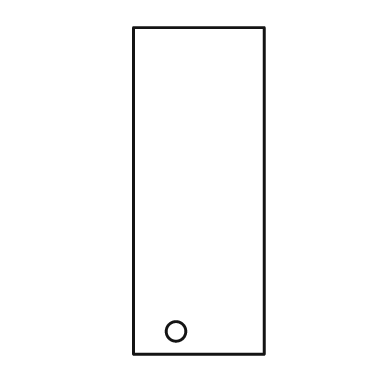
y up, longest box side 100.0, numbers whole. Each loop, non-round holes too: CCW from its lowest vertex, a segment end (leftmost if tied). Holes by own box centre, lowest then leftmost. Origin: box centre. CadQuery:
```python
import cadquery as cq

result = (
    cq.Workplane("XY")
    .moveTo(-20.0, -50.0)
    .lineTo(20.0, -50.0)
    .lineTo(20.0, 50.0)
    .lineTo(-20.0, 50.0)
    .close()
    .moveTo(-7.0, -43.0)
    .circle(3.0)
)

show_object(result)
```